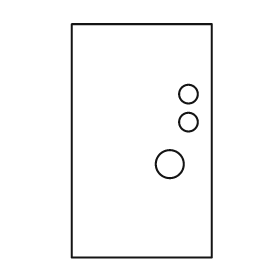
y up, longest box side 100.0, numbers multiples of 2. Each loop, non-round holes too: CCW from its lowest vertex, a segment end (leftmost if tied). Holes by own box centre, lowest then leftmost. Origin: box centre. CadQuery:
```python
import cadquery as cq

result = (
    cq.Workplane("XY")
    .moveTo(-30.0, -50.0)
    .lineTo(30.0, -50.0)
    .lineTo(30.0, 50.0)
    .lineTo(-30.0, 50.0)
    .close()
    .moveTo(12.0, -10.0)
    .circle(6.0)
    .moveTo(20.0, 8.0)
    .circle(4.0)
    .moveTo(20.0, 20.0)
    .circle(4.0)
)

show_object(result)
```